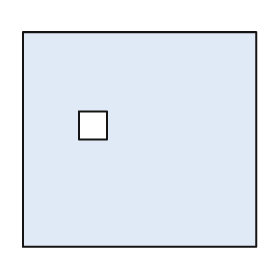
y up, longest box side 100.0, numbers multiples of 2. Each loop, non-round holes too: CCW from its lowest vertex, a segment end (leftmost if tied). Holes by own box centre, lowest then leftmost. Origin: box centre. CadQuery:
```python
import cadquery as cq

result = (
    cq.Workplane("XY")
    .moveTo(-50.0, -46.0)
    .lineTo(50.0, -46.0)
    .lineTo(50.0, 46.0)
    .lineTo(-50.0, 46.0)
    .close()
    .moveTo(-26.0, 0.0)
    .lineTo(-14.0, 0.0)
    .lineTo(-14.0, 12.0)
    .lineTo(-26.0, 12.0)
    .close()
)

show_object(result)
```